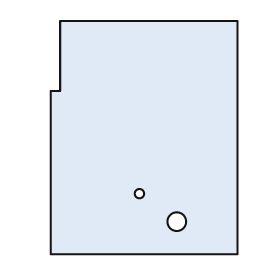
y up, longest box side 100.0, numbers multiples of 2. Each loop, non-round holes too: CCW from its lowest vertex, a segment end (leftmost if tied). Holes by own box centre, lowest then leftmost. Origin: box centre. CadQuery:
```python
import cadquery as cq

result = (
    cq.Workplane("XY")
    .moveTo(-40.0, -50.0)
    .lineTo(40.0, -50.0)
    .lineTo(40.0, 50.0)
    .lineTo(-36.0, 50.0)
    .lineTo(-36.0, 20.0)
    .lineTo(-40.0, 20.0)
    .close()
    .moveTo(14.0, -36.0)
    .circle(4.0)
    .moveTo(-2.0, -24.0)
    .circle(2.0)
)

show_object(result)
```